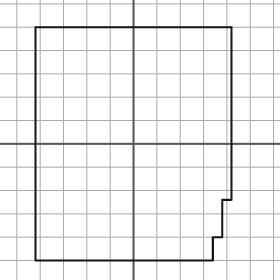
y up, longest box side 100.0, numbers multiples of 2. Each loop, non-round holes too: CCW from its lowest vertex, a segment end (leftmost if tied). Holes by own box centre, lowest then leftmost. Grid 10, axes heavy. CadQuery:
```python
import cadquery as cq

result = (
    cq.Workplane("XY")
    .moveTo(-42.0, -50.0)
    .lineTo(34.0, -50.0)
    .lineTo(34.0, -40.0)
    .lineTo(38.0, -40.0)
    .lineTo(38.0, -24.0)
    .lineTo(42.0, -24.0)
    .lineTo(42.0, 50.0)
    .lineTo(-42.0, 50.0)
    .close()
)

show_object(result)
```